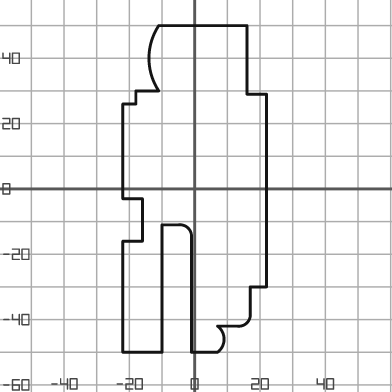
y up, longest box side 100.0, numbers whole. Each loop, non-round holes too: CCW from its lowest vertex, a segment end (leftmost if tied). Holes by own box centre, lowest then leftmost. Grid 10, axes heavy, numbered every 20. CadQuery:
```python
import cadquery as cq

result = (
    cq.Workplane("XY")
    .moveTo(-22.0, -50.0)
    .lineTo(-10.0, -50.0)
    .lineTo(-10.0, -11.0)
    .lineTo(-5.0, -11.0)
    .threePointArc((-2.0, -12.0), (-1.0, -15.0))
    .lineTo(-1.0, -50.0)
    .lineTo(7.0, -50.0)
    .threePointArc((9.0, -46.0), (7.0, -42.0))
    .lineTo(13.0, -42.0)
    .threePointArc((16.0, -41.0), (17.0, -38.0))
    .lineTo(17.0, -30.0)
    .lineTo(22.0, -30.0)
    .lineTo(22.0, 29.0)
    .lineTo(16.0, 29.0)
    .lineTo(16.0, 50.0)
    .lineTo(-11.0, 50.0)
    .threePointArc((-14.0, 40.0), (-11.0, 30.0))
    .lineTo(-18.0, 30.0)
    .lineTo(-18.0, 26.0)
    .lineTo(-22.0, 26.0)
    .lineTo(-22.0, -3.0)
    .lineTo(-16.0, -3.0)
    .lineTo(-16.0, -16.0)
    .lineTo(-22.0, -16.0)
    .close()
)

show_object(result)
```